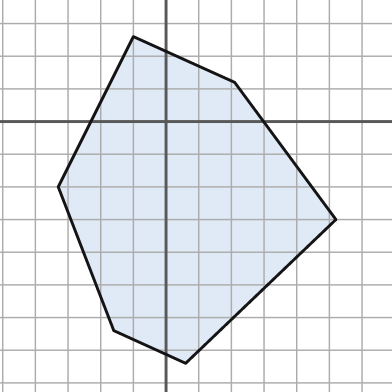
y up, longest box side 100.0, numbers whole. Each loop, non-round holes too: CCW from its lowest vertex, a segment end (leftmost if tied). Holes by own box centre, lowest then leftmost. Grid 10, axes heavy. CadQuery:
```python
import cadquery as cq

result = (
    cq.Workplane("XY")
    .moveTo(6.0, -74.0)
    .lineTo(52.0, -30.0)
    .lineTo(21.0, 12.0)
    .lineTo(-10.0, 26.0)
    .lineTo(-33.0, -20.0)
    .lineTo(-16.0, -64.0)
    .close()
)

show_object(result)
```